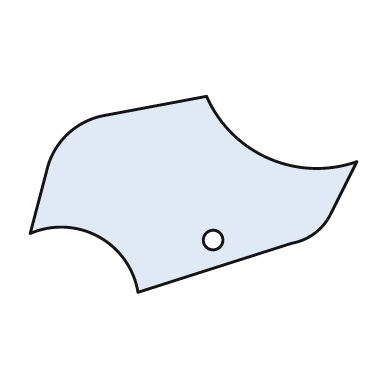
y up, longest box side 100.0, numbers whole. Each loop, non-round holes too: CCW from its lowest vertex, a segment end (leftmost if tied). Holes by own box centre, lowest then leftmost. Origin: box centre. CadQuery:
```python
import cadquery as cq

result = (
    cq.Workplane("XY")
    .moveTo(-17.0, -30.0)
    .lineTo(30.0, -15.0)
    .threePointArc((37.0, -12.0), (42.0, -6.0))
    .lineTo(50.0, 10.0)
    .threePointArc((23.0, 11.0), (4.0, 30.0))
    .lineTo(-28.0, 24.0)
    .threePointArc((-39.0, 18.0), (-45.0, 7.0))
    .lineTo(-50.0, -12.0)
    .threePointArc((-29.0, -13.0), (-17.0, -30.0))
    .close()
    .moveTo(6.0, -14.0)
    .circle(3.0)
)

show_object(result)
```